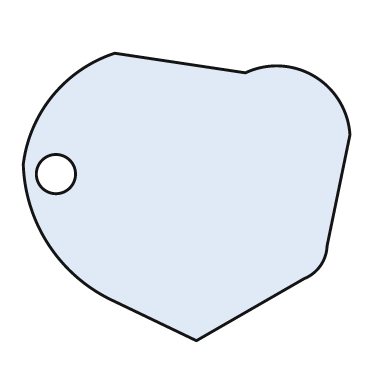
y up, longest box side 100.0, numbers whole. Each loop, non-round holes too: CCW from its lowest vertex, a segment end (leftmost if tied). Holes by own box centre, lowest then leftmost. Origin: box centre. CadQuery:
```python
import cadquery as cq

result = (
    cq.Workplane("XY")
    .moveTo(3.0, -44.0)
    .lineTo(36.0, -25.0)
    .threePointArc((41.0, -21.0), (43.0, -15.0))
    .lineTo(50.0, 19.0)
    .threePointArc((39.0, 37.0), (18.0, 38.0))
    .lineTo(-22.0, 44.0)
    .threePointArc((-41.0, 31.0), (-50.0, 10.0))
    .threePointArc((-42.0, -15.0), (-22.0, -32.0))
    .close()
    .moveTo(-40.0, 7.0)
    .circle(6.0)
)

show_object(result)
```